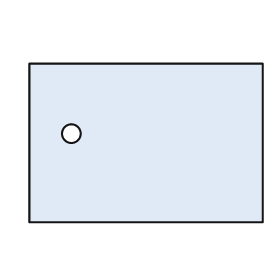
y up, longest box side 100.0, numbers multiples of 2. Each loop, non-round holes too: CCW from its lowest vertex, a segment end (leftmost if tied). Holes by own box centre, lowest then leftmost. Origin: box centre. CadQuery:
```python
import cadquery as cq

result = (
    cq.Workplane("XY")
    .moveTo(-50.0, -34.0)
    .lineTo(50.0, -34.0)
    .lineTo(50.0, 34.0)
    .lineTo(-50.0, 34.0)
    .close()
    .moveTo(-32.0, 4.0)
    .circle(4.0)
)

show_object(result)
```